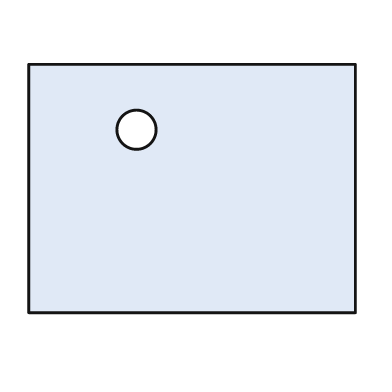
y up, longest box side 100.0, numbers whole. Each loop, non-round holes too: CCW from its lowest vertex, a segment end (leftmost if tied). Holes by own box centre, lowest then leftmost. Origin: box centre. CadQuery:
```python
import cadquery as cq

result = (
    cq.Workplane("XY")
    .moveTo(-50.0, -38.0)
    .lineTo(50.0, -38.0)
    .lineTo(50.0, 38.0)
    .lineTo(-50.0, 38.0)
    .close()
    .moveTo(-17.0, 18.0)
    .circle(6.0)
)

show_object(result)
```